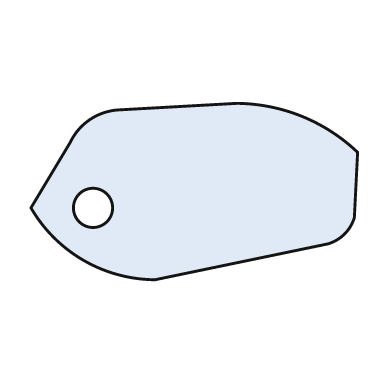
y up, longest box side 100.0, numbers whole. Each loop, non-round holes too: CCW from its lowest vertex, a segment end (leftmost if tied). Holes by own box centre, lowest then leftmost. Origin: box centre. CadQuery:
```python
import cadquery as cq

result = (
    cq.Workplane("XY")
    .moveTo(-12.0, -27.0)
    .lineTo(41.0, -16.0)
    .threePointArc((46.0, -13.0), (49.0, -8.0))
    .lineTo(50.0, 12.0)
    .threePointArc((33.0, 23.0), (13.0, 27.0))
    .lineTo(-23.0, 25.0)
    .threePointArc((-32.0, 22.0), (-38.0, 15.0))
    .lineTo(-50.0, -5.0)
    .threePointArc((-34.0, -21.0), (-12.0, -27.0))
    .close()
    .moveTo(-31.0, -5.0)
    .circle(6.0)
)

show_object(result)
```